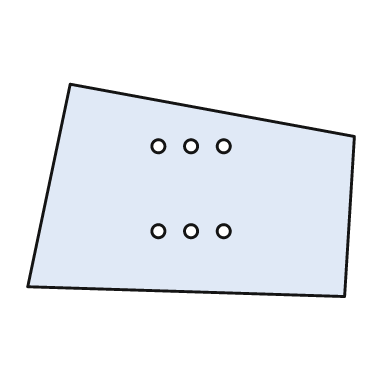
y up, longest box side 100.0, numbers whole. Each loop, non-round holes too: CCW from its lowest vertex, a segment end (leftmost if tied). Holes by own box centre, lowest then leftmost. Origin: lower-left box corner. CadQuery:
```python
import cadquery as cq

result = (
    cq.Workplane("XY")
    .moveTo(97.0, 0.0)
    .lineTo(100.0, 49.0)
    .lineTo(13.0, 65.0)
    .lineTo(0.0, 3.0)
    .close()
    .moveTo(40.0, 20.0)
    .circle(2.0)
    .moveTo(50.0, 20.0)
    .circle(2.0)
    .moveTo(60.0, 20.0)
    .circle(2.0)
    .moveTo(40.0, 46.0)
    .circle(2.0)
    .moveTo(50.0, 46.0)
    .circle(2.0)
    .moveTo(60.0, 46.0)
    .circle(2.0)
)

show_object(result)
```